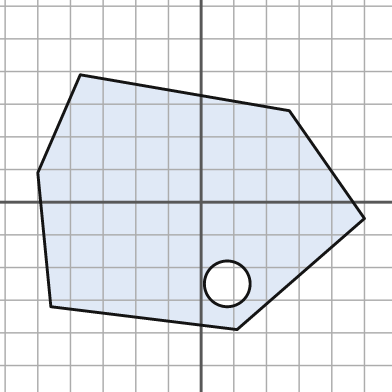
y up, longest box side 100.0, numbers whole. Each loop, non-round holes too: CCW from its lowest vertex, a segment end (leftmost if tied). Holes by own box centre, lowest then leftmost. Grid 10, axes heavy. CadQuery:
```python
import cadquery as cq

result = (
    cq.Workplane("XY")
    .moveTo(11.0, -39.0)
    .lineTo(50.0, -5.0)
    .lineTo(27.0, 28.0)
    .lineTo(-37.0, 39.0)
    .lineTo(-50.0, 9.0)
    .lineTo(-46.0, -32.0)
    .close()
    .moveTo(8.0, -25.0)
    .circle(7.0)
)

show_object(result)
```